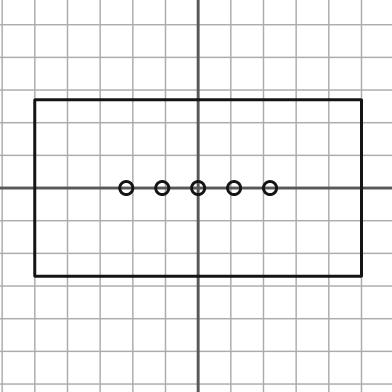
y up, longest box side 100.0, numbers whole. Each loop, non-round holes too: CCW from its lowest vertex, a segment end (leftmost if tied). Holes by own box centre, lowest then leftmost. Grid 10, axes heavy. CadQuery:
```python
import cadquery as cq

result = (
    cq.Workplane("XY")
    .moveTo(-50.0, -27.0)
    .lineTo(50.0, -27.0)
    .lineTo(50.0, 27.0)
    .lineTo(-50.0, 27.0)
    .close()
    .moveTo(-22.0, 0.0)
    .circle(2.0)
    .moveTo(-11.0, 0.0)
    .circle(2.0)
    .moveTo(0.0, 0.0)
    .circle(2.0)
    .moveTo(11.0, 0.0)
    .circle(2.0)
    .moveTo(22.0, 0.0)
    .circle(2.0)
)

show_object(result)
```